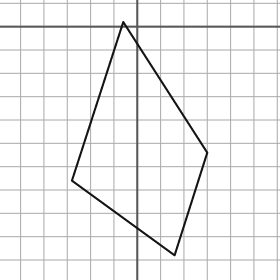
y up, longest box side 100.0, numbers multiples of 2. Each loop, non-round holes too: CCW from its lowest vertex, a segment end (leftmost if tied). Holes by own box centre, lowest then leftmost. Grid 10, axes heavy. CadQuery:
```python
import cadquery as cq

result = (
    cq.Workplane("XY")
    .moveTo(16.0, -98.0)
    .lineTo(30.0, -54.0)
    .lineTo(-6.0, 2.0)
    .lineTo(-28.0, -66.0)
    .close()
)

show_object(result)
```